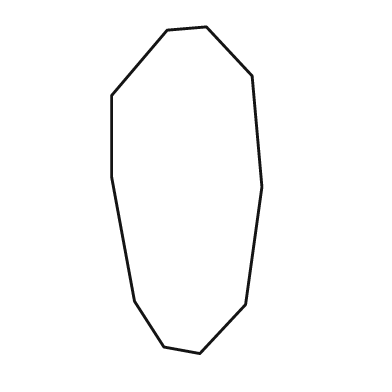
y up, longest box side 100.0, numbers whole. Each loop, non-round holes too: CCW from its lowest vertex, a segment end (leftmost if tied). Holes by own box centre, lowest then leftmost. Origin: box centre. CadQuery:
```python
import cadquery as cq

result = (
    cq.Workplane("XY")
    .moveTo(4.0, -50.0)
    .lineTo(18.0, -35.0)
    .lineTo(23.0, 1.0)
    .lineTo(20.0, 35.0)
    .lineTo(6.0, 50.0)
    .lineTo(-6.0, 49.0)
    .lineTo(-23.0, 29.0)
    .lineTo(-23.0, 4.0)
    .lineTo(-16.0, -34.0)
    .lineTo(-7.0, -48.0)
    .close()
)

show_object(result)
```